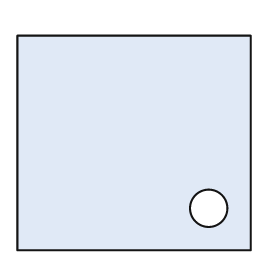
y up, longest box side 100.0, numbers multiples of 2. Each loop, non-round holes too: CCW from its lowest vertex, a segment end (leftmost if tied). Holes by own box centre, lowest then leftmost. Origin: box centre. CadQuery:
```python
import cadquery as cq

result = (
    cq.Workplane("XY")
    .moveTo(-50.0, -46.0)
    .lineTo(50.0, -46.0)
    .lineTo(50.0, 46.0)
    .lineTo(-50.0, 46.0)
    .close()
    .moveTo(32.0, -28.0)
    .circle(8.0)
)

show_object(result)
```